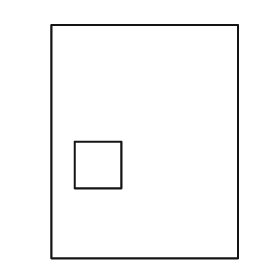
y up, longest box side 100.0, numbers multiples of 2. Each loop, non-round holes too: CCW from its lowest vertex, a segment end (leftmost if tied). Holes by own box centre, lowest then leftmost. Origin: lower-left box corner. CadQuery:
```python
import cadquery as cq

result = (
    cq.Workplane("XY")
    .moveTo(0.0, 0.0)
    .lineTo(80.0, 0.0)
    .lineTo(80.0, 100.0)
    .lineTo(0.0, 100.0)
    .close()
    .moveTo(10.0, 30.0)
    .lineTo(30.0, 30.0)
    .lineTo(30.0, 50.0)
    .lineTo(10.0, 50.0)
    .close()
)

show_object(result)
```